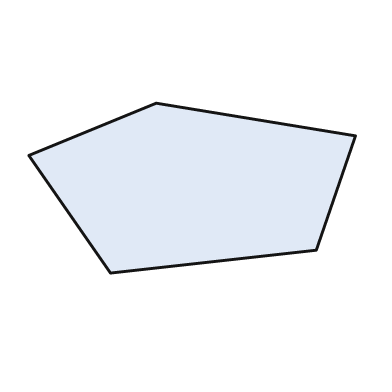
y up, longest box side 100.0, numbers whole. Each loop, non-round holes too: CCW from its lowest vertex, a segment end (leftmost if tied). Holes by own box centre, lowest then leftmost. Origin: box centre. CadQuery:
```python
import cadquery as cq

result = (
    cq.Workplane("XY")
    .moveTo(-25.0, -26.0)
    .lineTo(38.0, -19.0)
    .lineTo(50.0, 16.0)
    .lineTo(-11.0, 26.0)
    .lineTo(-50.0, 10.0)
    .close()
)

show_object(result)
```